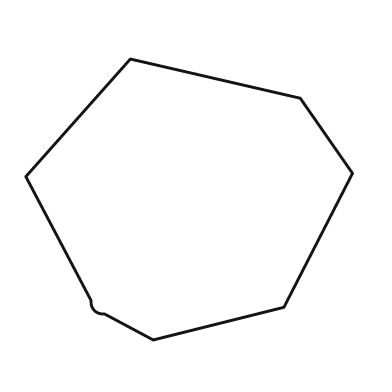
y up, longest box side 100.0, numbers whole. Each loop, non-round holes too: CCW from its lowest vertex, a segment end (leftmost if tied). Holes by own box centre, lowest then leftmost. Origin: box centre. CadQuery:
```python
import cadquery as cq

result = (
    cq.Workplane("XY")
    .moveTo(-11.0, -43.0)
    .lineTo(29.0, -33.0)
    .lineTo(50.0, 8.0)
    .lineTo(34.0, 31.0)
    .lineTo(-18.0, 43.0)
    .lineTo(-50.0, 7.0)
    .lineTo(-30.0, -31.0)
    .threePointArc((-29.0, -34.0), (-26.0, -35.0))
    .close()
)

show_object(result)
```